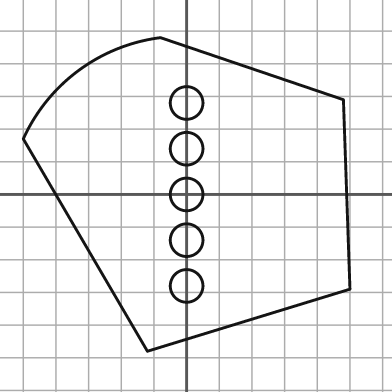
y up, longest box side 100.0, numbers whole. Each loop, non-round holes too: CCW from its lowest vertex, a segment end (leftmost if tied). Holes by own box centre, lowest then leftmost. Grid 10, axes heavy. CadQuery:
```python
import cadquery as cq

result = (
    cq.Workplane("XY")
    .moveTo(-12.0, -48.0)
    .lineTo(50.0, -29.0)
    .lineTo(48.0, 29.0)
    .lineTo(-8.0, 48.0)
    .threePointArc((-33.0, 38.0), (-50.0, 17.0))
    .close()
    .moveTo(0.0, -28.0)
    .circle(5.0)
    .moveTo(0.0, -14.0)
    .circle(5.0)
    .moveTo(0.0, 0.0)
    .circle(5.0)
    .moveTo(0.0, 14.0)
    .circle(5.0)
    .moveTo(0.0, 28.0)
    .circle(5.0)
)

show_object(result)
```